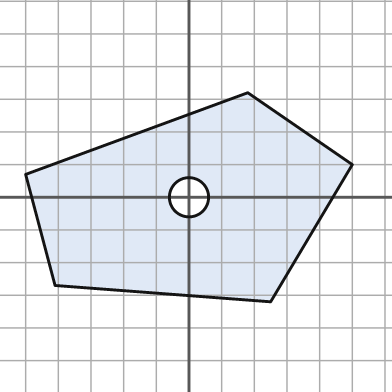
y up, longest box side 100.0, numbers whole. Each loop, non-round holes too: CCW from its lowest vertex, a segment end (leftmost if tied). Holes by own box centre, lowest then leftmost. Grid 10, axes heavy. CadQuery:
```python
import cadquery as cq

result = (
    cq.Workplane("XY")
    .moveTo(25.0, -32.0)
    .lineTo(50.0, 10.0)
    .lineTo(18.0, 32.0)
    .lineTo(-50.0, 7.0)
    .lineTo(-41.0, -27.0)
    .close()
    .moveTo(0.0, 0.0)
    .circle(6.0)
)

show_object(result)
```